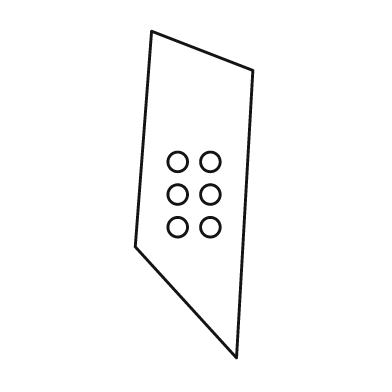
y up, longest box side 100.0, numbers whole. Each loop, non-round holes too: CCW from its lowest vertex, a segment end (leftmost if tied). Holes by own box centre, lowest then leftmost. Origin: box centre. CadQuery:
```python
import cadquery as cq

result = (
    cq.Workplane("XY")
    .moveTo(13.0, -50.0)
    .lineTo(18.0, 38.0)
    .lineTo(-13.0, 50.0)
    .lineTo(-18.0, -16.0)
    .close()
    .moveTo(-5.0, -10.0)
    .circle(3.0)
    .moveTo(5.0, -10.0)
    .circle(3.0)
    .moveTo(-5.0, 0.0)
    .circle(3.0)
    .moveTo(5.0, 0.0)
    .circle(3.0)
    .moveTo(-5.0, 10.0)
    .circle(3.0)
    .moveTo(5.0, 10.0)
    .circle(3.0)
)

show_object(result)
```